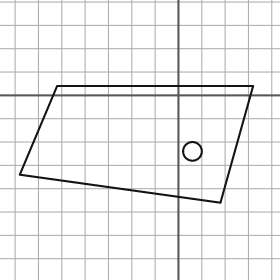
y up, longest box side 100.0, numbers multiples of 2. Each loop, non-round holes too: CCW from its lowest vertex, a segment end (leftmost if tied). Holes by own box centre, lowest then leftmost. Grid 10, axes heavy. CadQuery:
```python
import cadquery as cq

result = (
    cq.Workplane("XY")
    .moveTo(18.0, -46.0)
    .lineTo(32.0, 4.0)
    .lineTo(-52.0, 4.0)
    .lineTo(-68.0, -34.0)
    .close()
    .moveTo(6.0, -24.0)
    .circle(4.0)
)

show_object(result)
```